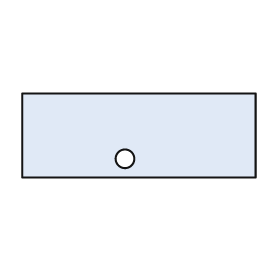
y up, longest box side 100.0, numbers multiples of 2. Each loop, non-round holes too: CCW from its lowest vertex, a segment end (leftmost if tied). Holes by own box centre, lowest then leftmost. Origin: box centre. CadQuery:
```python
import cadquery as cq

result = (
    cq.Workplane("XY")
    .moveTo(-50.0, -18.0)
    .lineTo(50.0, -18.0)
    .lineTo(50.0, 18.0)
    .lineTo(-50.0, 18.0)
    .close()
    .moveTo(-6.0, -10.0)
    .circle(4.0)
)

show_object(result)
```